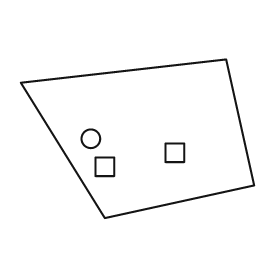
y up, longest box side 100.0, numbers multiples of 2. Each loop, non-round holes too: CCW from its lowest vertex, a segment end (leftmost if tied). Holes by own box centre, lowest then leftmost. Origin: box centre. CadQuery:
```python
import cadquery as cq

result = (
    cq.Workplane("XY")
    .moveTo(-14.0, -34.0)
    .lineTo(50.0, -20.0)
    .lineTo(38.0, 34.0)
    .lineTo(-50.0, 24.0)
    .close()
    .moveTo(-18.0, -16.0)
    .lineTo(-10.0, -16.0)
    .lineTo(-10.0, -8.0)
    .lineTo(-18.0, -8.0)
    .close()
    .moveTo(12.0, -10.0)
    .lineTo(20.0, -10.0)
    .lineTo(20.0, -2.0)
    .lineTo(12.0, -2.0)
    .close()
    .moveTo(-20.0, 0.0)
    .circle(4.0)
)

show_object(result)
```